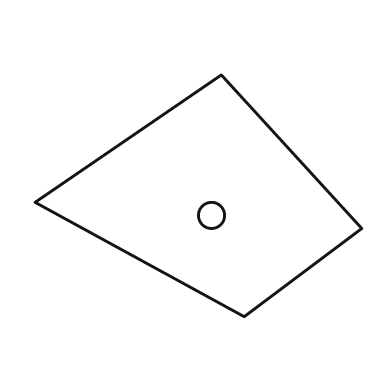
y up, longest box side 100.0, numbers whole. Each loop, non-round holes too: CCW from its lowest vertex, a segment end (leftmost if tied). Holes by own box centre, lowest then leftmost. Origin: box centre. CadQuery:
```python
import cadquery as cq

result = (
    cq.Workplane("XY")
    .moveTo(14.0, -37.0)
    .lineTo(50.0, -10.0)
    .lineTo(7.0, 37.0)
    .lineTo(-50.0, -2.0)
    .close()
    .moveTo(4.0, -6.0)
    .circle(4.0)
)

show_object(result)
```